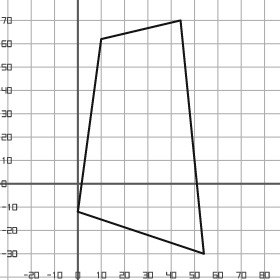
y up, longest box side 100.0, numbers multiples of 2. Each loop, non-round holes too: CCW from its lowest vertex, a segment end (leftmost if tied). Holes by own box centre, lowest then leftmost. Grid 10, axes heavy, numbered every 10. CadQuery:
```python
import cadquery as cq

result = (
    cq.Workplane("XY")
    .moveTo(54.0, -30.0)
    .lineTo(44.0, 70.0)
    .lineTo(10.0, 62.0)
    .lineTo(0.0, -12.0)
    .close()
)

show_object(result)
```